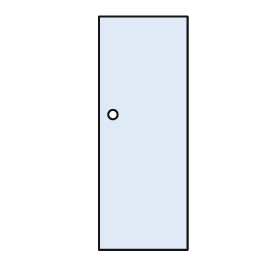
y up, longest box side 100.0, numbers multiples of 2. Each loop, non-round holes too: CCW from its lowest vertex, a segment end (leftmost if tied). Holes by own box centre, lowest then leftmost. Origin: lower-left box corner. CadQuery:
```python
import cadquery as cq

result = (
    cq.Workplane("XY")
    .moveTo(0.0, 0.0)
    .lineTo(38.0, 0.0)
    .lineTo(38.0, 100.0)
    .lineTo(0.0, 100.0)
    .close()
    .moveTo(6.0, 58.0)
    .circle(2.0)
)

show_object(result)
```